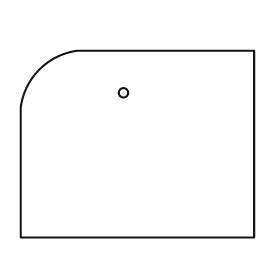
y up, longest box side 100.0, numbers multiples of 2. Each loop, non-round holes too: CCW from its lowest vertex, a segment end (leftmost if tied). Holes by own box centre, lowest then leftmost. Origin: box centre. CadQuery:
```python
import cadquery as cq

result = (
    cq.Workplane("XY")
    .moveTo(-50.0, -40.0)
    .lineTo(50.0, -40.0)
    .lineTo(50.0, 40.0)
    .lineTo(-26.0, 40.0)
    .threePointArc((-42.0, 32.0), (-50.0, 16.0))
    .close()
    .moveTo(-6.0, 22.0)
    .circle(2.0)
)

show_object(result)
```